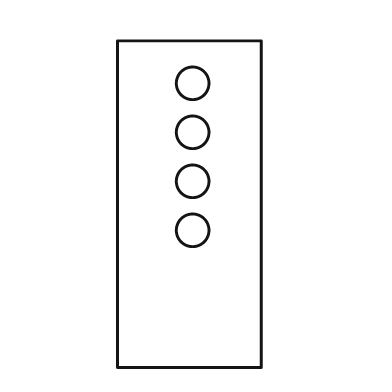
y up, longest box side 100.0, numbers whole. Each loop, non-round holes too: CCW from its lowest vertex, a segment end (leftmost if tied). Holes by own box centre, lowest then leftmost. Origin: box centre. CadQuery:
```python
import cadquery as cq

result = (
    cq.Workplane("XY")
    .moveTo(-22.0, -50.0)
    .lineTo(22.0, -50.0)
    .lineTo(22.0, 50.0)
    .lineTo(-22.0, 50.0)
    .close()
    .moveTo(1.0, -8.0)
    .circle(5.0)
    .moveTo(1.0, 7.0)
    .circle(5.0)
    .moveTo(1.0, 22.0)
    .circle(5.0)
    .moveTo(1.0, 37.0)
    .circle(5.0)
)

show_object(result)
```